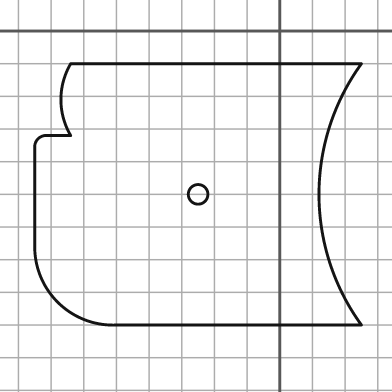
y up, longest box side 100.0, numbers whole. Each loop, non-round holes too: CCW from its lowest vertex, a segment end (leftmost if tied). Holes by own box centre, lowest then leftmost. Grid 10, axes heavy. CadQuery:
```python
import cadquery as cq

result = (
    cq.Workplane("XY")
    .moveTo(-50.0, -90.0)
    .lineTo(25.0, -90.0)
    .threePointArc((12.0, -50.0), (25.0, -10.0))
    .lineTo(-64.0, -10.0)
    .threePointArc((-67.0, -21.0), (-64.0, -32.0))
    .lineTo(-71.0, -32.0)
    .threePointArc((-74.0, -33.0), (-75.0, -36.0))
    .lineTo(-75.0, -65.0)
    .threePointArc((-68.0, -83.0), (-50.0, -90.0))
    .close()
    .moveTo(-25.0, -50.0)
    .circle(3.0)
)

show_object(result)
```